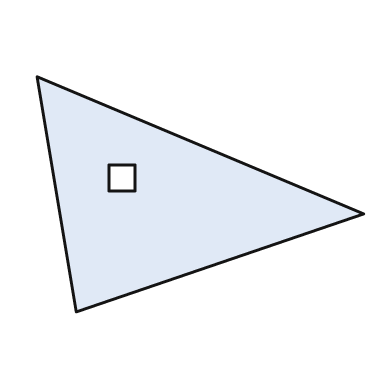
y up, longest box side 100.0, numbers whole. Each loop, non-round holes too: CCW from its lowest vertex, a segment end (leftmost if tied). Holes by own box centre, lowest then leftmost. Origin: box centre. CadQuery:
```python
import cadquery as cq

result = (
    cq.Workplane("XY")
    .moveTo(-38.0, -36.0)
    .lineTo(50.0, -6.0)
    .lineTo(-50.0, 36.0)
    .close()
    .moveTo(-28.0, 1.0)
    .lineTo(-20.0, 1.0)
    .lineTo(-20.0, 9.0)
    .lineTo(-28.0, 9.0)
    .close()
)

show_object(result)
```